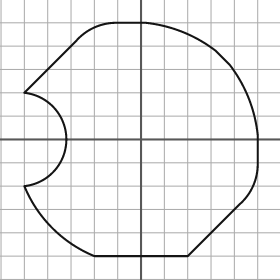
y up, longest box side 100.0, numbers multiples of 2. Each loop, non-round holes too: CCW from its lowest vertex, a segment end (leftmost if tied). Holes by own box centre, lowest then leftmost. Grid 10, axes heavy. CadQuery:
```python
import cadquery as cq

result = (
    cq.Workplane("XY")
    .moveTo(-20.0, -50.0)
    .lineTo(20.0, -50.0)
    .lineTo(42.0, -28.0)
    .threePointArc((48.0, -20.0), (50.0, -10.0))
    .lineTo(50.0, 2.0)
    .threePointArc((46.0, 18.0), (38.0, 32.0))
    .lineTo(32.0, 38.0)
    .threePointArc((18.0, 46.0), (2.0, 50.0))
    .lineTo(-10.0, 50.0)
    .threePointArc((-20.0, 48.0), (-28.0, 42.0))
    .lineTo(-50.0, 20.0)
    .threePointArc((-32.0, 0.0), (-50.0, -20.0))
    .threePointArc((-38.0, -38.0), (-20.0, -50.0))
    .close()
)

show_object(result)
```